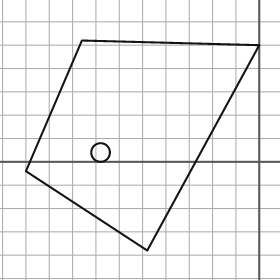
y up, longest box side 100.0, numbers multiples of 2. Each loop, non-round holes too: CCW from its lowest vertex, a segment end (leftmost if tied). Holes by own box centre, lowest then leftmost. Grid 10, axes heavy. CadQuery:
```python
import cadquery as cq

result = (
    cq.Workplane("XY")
    .moveTo(-48.0, -38.0)
    .lineTo(0.0, 50.0)
    .lineTo(-76.0, 52.0)
    .lineTo(-100.0, -4.0)
    .close()
    .moveTo(-68.0, 4.0)
    .circle(4.0)
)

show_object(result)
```